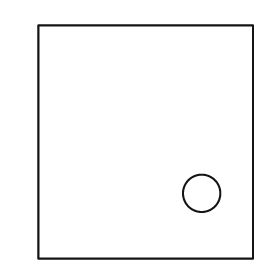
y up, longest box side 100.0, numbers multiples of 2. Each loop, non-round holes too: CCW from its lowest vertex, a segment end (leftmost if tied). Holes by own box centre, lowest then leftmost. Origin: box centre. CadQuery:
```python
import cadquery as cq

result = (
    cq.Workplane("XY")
    .moveTo(-46.0, -50.0)
    .lineTo(46.0, -50.0)
    .lineTo(46.0, 50.0)
    .lineTo(-46.0, 50.0)
    .close()
    .moveTo(24.0, -22.0)
    .circle(8.0)
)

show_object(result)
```